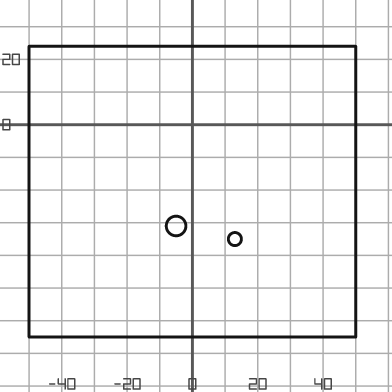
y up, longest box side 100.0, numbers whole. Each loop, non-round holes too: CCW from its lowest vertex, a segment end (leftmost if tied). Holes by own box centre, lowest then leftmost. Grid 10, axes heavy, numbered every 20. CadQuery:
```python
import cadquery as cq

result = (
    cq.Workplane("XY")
    .moveTo(-50.0, -65.0)
    .lineTo(50.0, -65.0)
    .lineTo(50.0, 24.0)
    .lineTo(-50.0, 24.0)
    .close()
    .moveTo(13.0, -35.0)
    .circle(2.0)
    .moveTo(-5.0, -31.0)
    .circle(3.0)
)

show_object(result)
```